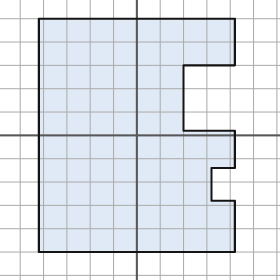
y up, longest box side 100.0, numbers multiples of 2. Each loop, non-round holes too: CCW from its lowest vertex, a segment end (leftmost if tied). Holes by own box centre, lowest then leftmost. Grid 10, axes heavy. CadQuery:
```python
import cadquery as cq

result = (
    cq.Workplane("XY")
    .moveTo(-42.0, -50.0)
    .lineTo(42.0, -50.0)
    .lineTo(42.0, -28.0)
    .lineTo(32.0, -28.0)
    .lineTo(32.0, -14.0)
    .lineTo(42.0, -14.0)
    .lineTo(42.0, 2.0)
    .lineTo(20.0, 2.0)
    .lineTo(20.0, 30.0)
    .lineTo(42.0, 30.0)
    .lineTo(42.0, 50.0)
    .lineTo(-42.0, 50.0)
    .close()
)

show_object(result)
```